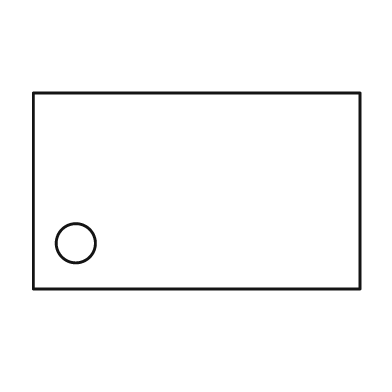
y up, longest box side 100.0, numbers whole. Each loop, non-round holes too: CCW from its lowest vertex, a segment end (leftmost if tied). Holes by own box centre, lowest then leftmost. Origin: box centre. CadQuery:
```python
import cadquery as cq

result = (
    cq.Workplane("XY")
    .moveTo(-50.0, -30.0)
    .lineTo(50.0, -30.0)
    .lineTo(50.0, 30.0)
    .lineTo(-50.0, 30.0)
    .close()
    .moveTo(-37.0, -16.0)
    .circle(6.0)
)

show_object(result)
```